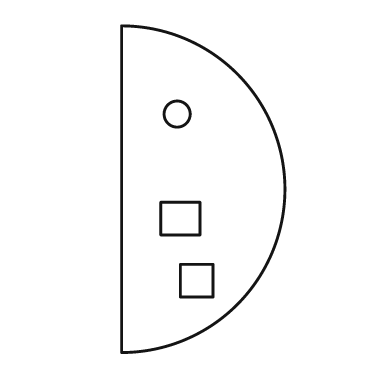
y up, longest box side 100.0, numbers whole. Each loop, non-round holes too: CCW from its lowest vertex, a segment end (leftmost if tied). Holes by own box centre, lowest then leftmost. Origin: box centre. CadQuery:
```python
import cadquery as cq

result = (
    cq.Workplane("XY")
    .moveTo(-25.0, -50.0)
    .threePointArc((25.0, 0.0), (-25.0, 50.0))
    .close()
    .moveTo(-7.0, -33.0)
    .lineTo(3.0, -33.0)
    .lineTo(3.0, -23.0)
    .lineTo(-7.0, -23.0)
    .close()
    .moveTo(-13.0, -14.0)
    .lineTo(-1.0, -14.0)
    .lineTo(-1.0, -4.0)
    .lineTo(-13.0, -4.0)
    .close()
    .moveTo(-8.0, 23.0)
    .circle(4.0)
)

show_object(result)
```